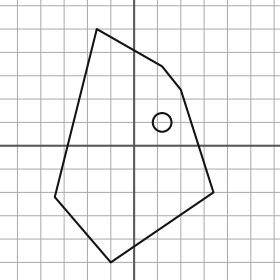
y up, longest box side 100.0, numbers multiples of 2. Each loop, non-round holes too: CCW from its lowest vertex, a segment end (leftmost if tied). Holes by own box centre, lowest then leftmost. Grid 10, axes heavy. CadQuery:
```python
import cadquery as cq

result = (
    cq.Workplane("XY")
    .moveTo(-10.0, -50.0)
    .lineTo(34.0, -20.0)
    .lineTo(20.0, 24.0)
    .lineTo(12.0, 34.0)
    .lineTo(-16.0, 50.0)
    .lineTo(-34.0, -22.0)
    .close()
    .moveTo(12.0, 10.0)
    .circle(4.0)
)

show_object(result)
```